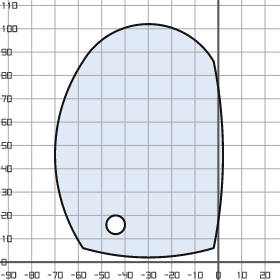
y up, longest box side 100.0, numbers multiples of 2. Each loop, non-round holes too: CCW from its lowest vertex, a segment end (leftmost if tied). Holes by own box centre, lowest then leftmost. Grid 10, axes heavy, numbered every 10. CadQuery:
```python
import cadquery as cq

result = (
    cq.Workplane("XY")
    .moveTo(-58.0, 6.0)
    .threePointArc((-30.0, 2.0), (-2.0, 6.0))
    .threePointArc((2.0, 46.0), (-2.0, 86.0))
    .threePointArc((-30.0, 102.0), (-58.0, 86.0))
    .threePointArc((-70.0, 46.0), (-58.0, 6.0))
    .close()
    .moveTo(-44.0, 16.0)
    .circle(4.0)
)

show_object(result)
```